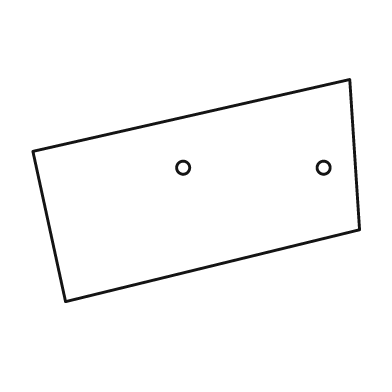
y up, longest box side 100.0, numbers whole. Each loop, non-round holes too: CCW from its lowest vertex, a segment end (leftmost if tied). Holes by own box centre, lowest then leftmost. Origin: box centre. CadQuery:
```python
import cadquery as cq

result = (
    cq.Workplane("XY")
    .moveTo(-40.0, -34.0)
    .lineTo(50.0, -12.0)
    .lineTo(47.0, 34.0)
    .lineTo(-50.0, 12.0)
    .close()
    .moveTo(-4.0, 7.0)
    .circle(2.0)
    .moveTo(39.0, 7.0)
    .circle(2.0)
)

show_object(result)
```